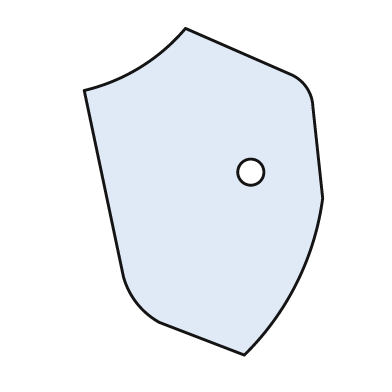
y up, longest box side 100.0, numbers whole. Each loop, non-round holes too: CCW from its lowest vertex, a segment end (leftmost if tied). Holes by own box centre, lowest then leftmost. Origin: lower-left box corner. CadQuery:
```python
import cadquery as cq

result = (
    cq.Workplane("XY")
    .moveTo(49.0, 0.0)
    .threePointArc((65.0, 22.0), (73.0, 48.0))
    .lineTo(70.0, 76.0)
    .threePointArc((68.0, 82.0), (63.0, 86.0))
    .lineTo(31.0, 100.0)
    .threePointArc((17.0, 88.0), (0.0, 81.0))
    .lineTo(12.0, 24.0)
    .threePointArc((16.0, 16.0), (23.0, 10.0))
    .close()
    .moveTo(51.0, 56.0)
    .circle(4.0)
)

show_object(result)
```